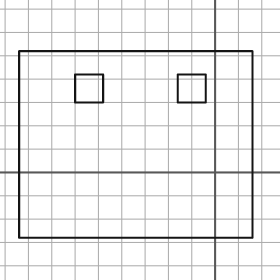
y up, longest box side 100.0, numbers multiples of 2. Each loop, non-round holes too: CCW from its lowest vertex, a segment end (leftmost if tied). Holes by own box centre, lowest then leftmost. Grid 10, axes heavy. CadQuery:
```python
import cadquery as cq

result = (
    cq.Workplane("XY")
    .moveTo(-84.0, -28.0)
    .lineTo(16.0, -28.0)
    .lineTo(16.0, 52.0)
    .lineTo(-84.0, 52.0)
    .close()
    .moveTo(-60.0, 30.0)
    .lineTo(-48.0, 30.0)
    .lineTo(-48.0, 42.0)
    .lineTo(-60.0, 42.0)
    .close()
    .moveTo(-16.0, 30.0)
    .lineTo(-4.0, 30.0)
    .lineTo(-4.0, 42.0)
    .lineTo(-16.0, 42.0)
    .close()
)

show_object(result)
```